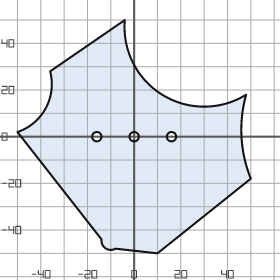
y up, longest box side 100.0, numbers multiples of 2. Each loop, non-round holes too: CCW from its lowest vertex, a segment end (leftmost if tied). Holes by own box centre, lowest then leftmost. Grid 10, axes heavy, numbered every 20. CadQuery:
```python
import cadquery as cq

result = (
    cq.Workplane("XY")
    .moveTo(10.0, -50.0)
    .lineTo(50.0, -18.0)
    .threePointArc((46.0, 0.0), (48.0, 18.0))
    .threePointArc((12.0, 18.0), (-4.0, 50.0))
    .lineTo(-36.0, 28.0)
    .threePointArc((-38.0, 12.0), (-50.0, 2.0))
    .lineTo(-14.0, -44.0)
    .threePointArc((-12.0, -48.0), (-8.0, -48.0))
    .close()
    .moveTo(-16.0, 0.0)
    .circle(2.0)
    .moveTo(0.0, 0.0)
    .circle(2.0)
    .moveTo(16.0, 0.0)
    .circle(2.0)
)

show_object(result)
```